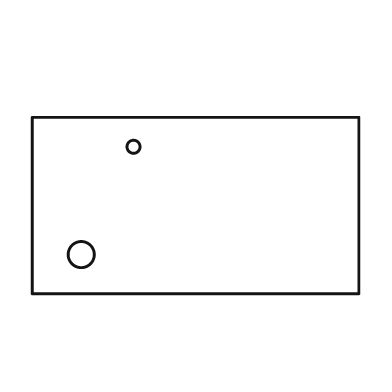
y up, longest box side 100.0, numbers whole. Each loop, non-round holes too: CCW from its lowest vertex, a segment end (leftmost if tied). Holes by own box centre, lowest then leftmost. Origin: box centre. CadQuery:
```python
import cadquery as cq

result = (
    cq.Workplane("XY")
    .moveTo(-50.0, -27.0)
    .lineTo(50.0, -27.0)
    .lineTo(50.0, 27.0)
    .lineTo(-50.0, 27.0)
    .close()
    .moveTo(-35.0, -15.0)
    .circle(4.0)
    .moveTo(-19.0, 18.0)
    .circle(2.0)
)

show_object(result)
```